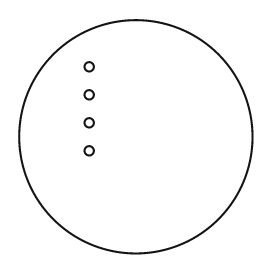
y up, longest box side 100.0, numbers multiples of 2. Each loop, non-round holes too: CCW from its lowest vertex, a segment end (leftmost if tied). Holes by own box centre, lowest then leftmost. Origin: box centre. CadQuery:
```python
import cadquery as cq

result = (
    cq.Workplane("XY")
    .moveTo(0.0, 0.0)
    .circle(50.0)
    .moveTo(-20.0, -6.0)
    .circle(2.0)
    .moveTo(-20.0, 6.0)
    .circle(2.0)
    .moveTo(-20.0, 18.0)
    .circle(2.0)
    .moveTo(-20.0, 30.0)
    .circle(2.0)
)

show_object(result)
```